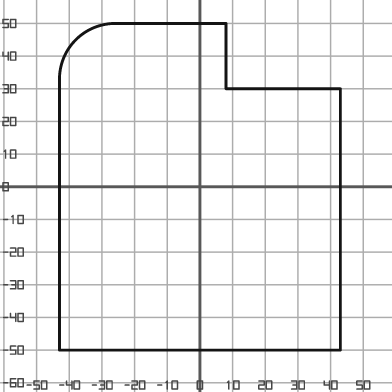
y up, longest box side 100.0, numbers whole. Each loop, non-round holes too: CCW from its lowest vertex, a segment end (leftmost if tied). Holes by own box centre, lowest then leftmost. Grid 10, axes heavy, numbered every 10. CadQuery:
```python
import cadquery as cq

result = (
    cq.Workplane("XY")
    .moveTo(-43.0, -50.0)
    .lineTo(43.0, -50.0)
    .lineTo(43.0, 30.0)
    .lineTo(8.0, 30.0)
    .lineTo(8.0, 50.0)
    .lineTo(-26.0, 50.0)
    .threePointArc((-38.0, 45.0), (-43.0, 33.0))
    .close()
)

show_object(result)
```